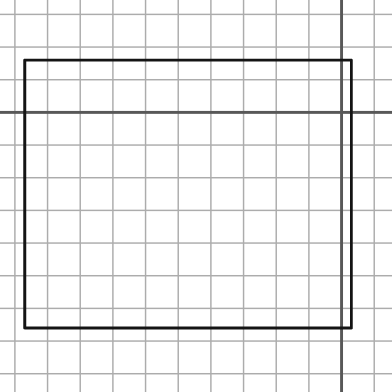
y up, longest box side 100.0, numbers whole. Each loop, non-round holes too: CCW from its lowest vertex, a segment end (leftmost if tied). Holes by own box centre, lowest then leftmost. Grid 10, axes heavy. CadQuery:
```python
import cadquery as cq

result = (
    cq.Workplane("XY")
    .moveTo(-97.0, -66.0)
    .lineTo(3.0, -66.0)
    .lineTo(3.0, 16.0)
    .lineTo(-97.0, 16.0)
    .close()
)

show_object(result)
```